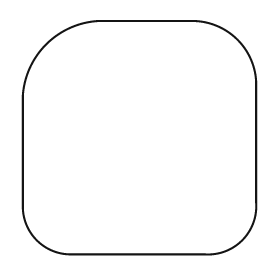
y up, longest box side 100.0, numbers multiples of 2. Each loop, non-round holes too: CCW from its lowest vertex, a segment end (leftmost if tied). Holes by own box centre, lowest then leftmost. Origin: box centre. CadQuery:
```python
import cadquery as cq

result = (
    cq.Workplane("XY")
    .moveTo(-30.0, -50.0)
    .lineTo(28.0, -50.0)
    .threePointArc((44.0, -44.0), (50.0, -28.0))
    .lineTo(50.0, 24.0)
    .threePointArc((42.0, 42.0), (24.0, 50.0))
    .lineTo(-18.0, 50.0)
    .threePointArc((-40.0, 40.0), (-50.0, 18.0))
    .lineTo(-50.0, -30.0)
    .threePointArc((-44.0, -44.0), (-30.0, -50.0))
    .close()
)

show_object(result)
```